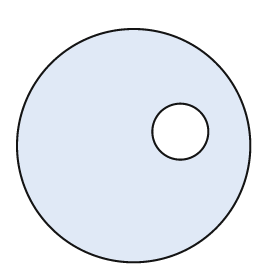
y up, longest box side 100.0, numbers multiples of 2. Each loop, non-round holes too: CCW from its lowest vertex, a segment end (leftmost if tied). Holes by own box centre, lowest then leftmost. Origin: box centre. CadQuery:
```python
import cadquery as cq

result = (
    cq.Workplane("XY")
    .moveTo(0.0, 0.0)
    .circle(50.0)
    .moveTo(20.0, 6.0)
    .circle(12.0)
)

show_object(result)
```